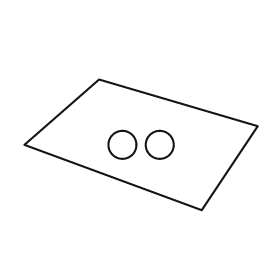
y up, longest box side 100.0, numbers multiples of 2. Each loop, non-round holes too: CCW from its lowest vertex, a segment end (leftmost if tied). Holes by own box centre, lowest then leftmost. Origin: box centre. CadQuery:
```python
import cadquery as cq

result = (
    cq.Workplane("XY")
    .moveTo(26.0, -28.0)
    .lineTo(50.0, 8.0)
    .lineTo(-18.0, 28.0)
    .lineTo(-50.0, 0.0)
    .close()
    .moveTo(-8.0, 0.0)
    .circle(6.0)
    .moveTo(8.0, 0.0)
    .circle(6.0)
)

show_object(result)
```